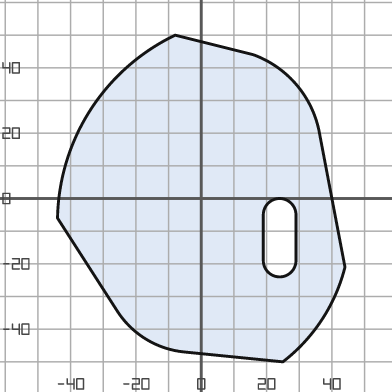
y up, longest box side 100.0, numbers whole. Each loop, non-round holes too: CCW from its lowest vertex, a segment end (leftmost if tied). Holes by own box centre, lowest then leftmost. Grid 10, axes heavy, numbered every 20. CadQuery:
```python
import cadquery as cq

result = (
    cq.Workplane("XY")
    .moveTo(25.0, -50.0)
    .threePointArc((37.0, -37.0), (44.0, -21.0))
    .lineTo(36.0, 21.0)
    .threePointArc((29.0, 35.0), (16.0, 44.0))
    .lineTo(-8.0, 50.0)
    .threePointArc((-34.0, 27.0), (-44.0, -6.0))
    .lineTo(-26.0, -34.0)
    .threePointArc((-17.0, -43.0), (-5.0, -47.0))
    .close()
    .moveTo(19.0, -19.0)
    .threePointArc((24.0, -24.0), (29.0, -19.0))
    .lineTo(29.0, -5.0)
    .threePointArc((24.0, 0.0), (19.0, -5.0))
    .close()
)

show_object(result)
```